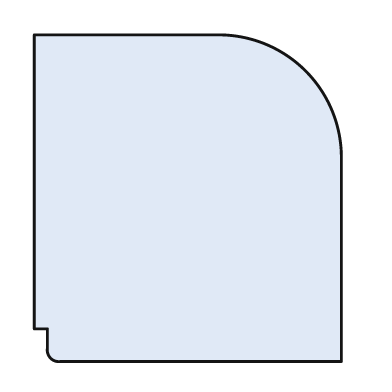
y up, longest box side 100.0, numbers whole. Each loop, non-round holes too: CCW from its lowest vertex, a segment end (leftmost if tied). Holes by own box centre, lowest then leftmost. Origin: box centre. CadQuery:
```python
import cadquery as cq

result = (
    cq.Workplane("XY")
    .moveTo(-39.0, -50.0)
    .lineTo(47.0, -50.0)
    .lineTo(47.0, 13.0)
    .threePointArc((36.0, 39.0), (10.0, 50.0))
    .lineTo(-47.0, 50.0)
    .lineTo(-47.0, -40.0)
    .lineTo(-43.0, -40.0)
    .lineTo(-43.0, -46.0)
    .threePointArc((-42.0, -49.0), (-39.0, -50.0))
    .close()
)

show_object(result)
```